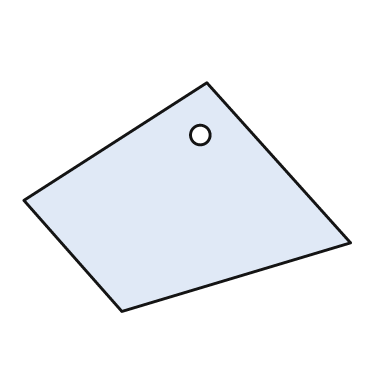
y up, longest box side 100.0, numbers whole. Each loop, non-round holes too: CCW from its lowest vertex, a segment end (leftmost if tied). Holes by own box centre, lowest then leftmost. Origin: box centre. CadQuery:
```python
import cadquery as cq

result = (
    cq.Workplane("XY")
    .moveTo(-20.0, -35.0)
    .lineTo(50.0, -14.0)
    .lineTo(6.0, 35.0)
    .lineTo(-50.0, -1.0)
    .close()
    .moveTo(4.0, 19.0)
    .circle(3.0)
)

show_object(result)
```